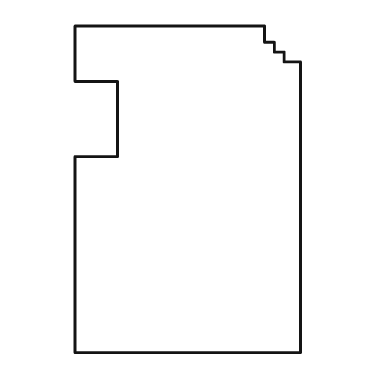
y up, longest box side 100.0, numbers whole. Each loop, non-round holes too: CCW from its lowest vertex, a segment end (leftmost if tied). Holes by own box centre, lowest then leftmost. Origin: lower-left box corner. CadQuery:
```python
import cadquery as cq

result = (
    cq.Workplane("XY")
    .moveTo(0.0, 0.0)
    .lineTo(69.0, 0.0)
    .lineTo(69.0, 89.0)
    .lineTo(64.0, 89.0)
    .lineTo(64.0, 92.0)
    .lineTo(61.0, 92.0)
    .lineTo(61.0, 95.0)
    .lineTo(58.0, 95.0)
    .lineTo(58.0, 100.0)
    .lineTo(0.0, 100.0)
    .lineTo(0.0, 83.0)
    .lineTo(13.0, 83.0)
    .lineTo(13.0, 60.0)
    .lineTo(0.0, 60.0)
    .close()
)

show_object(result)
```